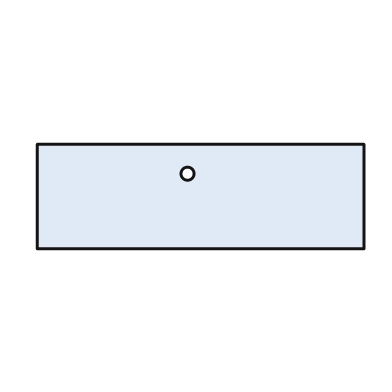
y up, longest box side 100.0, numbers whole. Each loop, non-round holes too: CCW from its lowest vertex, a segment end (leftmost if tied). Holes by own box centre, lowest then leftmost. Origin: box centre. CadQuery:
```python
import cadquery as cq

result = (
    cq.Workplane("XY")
    .moveTo(-50.0, -16.0)
    .lineTo(50.0, -16.0)
    .lineTo(50.0, 16.0)
    .lineTo(-50.0, 16.0)
    .close()
    .moveTo(-4.0, 7.0)
    .circle(2.0)
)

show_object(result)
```